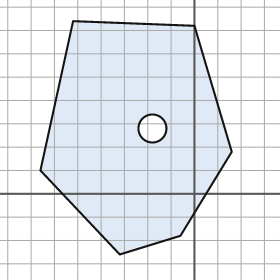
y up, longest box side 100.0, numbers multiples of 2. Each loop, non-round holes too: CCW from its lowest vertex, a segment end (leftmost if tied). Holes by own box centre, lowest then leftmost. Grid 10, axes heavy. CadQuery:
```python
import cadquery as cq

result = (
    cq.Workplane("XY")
    .moveTo(-32.0, -26.0)
    .lineTo(-6.0, -18.0)
    .lineTo(16.0, 18.0)
    .lineTo(0.0, 72.0)
    .lineTo(-52.0, 74.0)
    .lineTo(-66.0, 10.0)
    .close()
    .moveTo(-18.0, 28.0)
    .circle(6.0)
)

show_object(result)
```